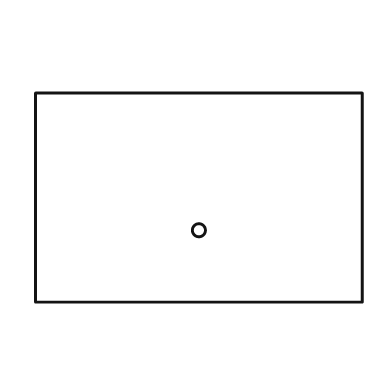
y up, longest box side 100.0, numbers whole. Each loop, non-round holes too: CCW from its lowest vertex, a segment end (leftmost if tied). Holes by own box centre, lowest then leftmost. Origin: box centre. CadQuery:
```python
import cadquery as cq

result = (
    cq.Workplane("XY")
    .moveTo(-50.0, -32.0)
    .lineTo(50.0, -32.0)
    .lineTo(50.0, 32.0)
    .lineTo(-50.0, 32.0)
    .close()
    .moveTo(0.0, -10.0)
    .circle(2.0)
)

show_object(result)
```